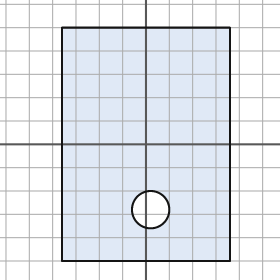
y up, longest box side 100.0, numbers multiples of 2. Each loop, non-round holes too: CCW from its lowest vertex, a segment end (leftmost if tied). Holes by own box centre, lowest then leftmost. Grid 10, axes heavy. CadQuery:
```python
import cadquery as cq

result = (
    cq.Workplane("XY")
    .moveTo(-36.0, -50.0)
    .lineTo(36.0, -50.0)
    .lineTo(36.0, 50.0)
    .lineTo(-36.0, 50.0)
    .close()
    .moveTo(2.0, -28.0)
    .circle(8.0)
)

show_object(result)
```